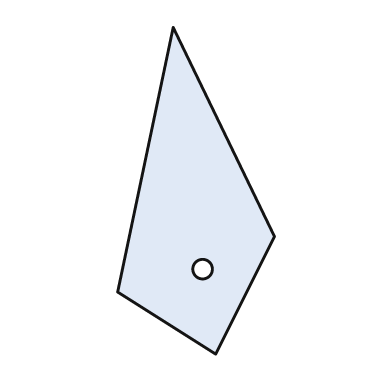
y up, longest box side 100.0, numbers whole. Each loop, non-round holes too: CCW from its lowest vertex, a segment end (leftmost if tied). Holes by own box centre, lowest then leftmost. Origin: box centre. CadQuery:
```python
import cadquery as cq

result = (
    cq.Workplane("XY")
    .moveTo(6.0, -50.0)
    .lineTo(24.0, -14.0)
    .lineTo(-7.0, 50.0)
    .lineTo(-24.0, -31.0)
    .close()
    .moveTo(2.0, -24.0)
    .circle(3.0)
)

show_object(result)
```